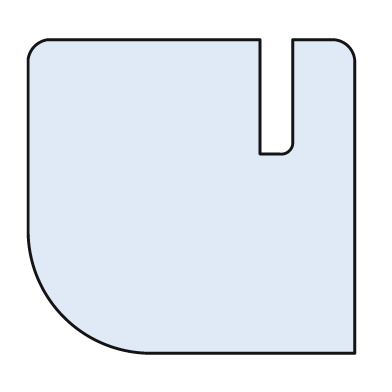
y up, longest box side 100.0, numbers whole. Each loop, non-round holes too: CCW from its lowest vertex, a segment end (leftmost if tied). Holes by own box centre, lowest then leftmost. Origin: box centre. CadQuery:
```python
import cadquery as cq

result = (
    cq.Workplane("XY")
    .moveTo(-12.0, -48.0)
    .lineTo(50.0, -48.0)
    .lineTo(50.0, 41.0)
    .threePointArc((48.0, 46.0), (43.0, 48.0))
    .lineTo(31.0, 48.0)
    .lineTo(31.0, 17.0)
    .threePointArc((30.0, 14.0), (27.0, 13.0))
    .lineTo(21.0, 13.0)
    .lineTo(21.0, 48.0)
    .lineTo(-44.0, 48.0)
    .threePointArc((-48.0, 46.0), (-50.0, 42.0))
    .lineTo(-50.0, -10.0)
    .threePointArc((-39.0, -37.0), (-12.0, -48.0))
    .close()
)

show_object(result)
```